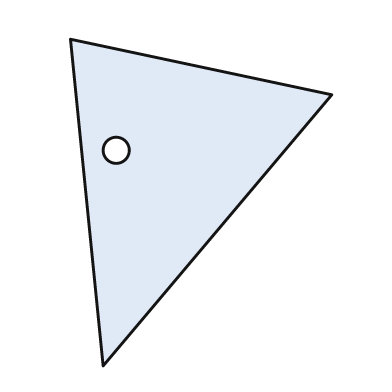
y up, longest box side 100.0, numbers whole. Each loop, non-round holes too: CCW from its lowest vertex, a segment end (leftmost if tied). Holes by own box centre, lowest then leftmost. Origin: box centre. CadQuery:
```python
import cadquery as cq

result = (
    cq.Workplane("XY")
    .moveTo(-30.0, -50.0)
    .lineTo(40.0, 33.0)
    .lineTo(-40.0, 50.0)
    .close()
    .moveTo(-26.0, 16.0)
    .circle(4.0)
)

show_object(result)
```